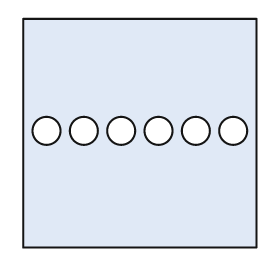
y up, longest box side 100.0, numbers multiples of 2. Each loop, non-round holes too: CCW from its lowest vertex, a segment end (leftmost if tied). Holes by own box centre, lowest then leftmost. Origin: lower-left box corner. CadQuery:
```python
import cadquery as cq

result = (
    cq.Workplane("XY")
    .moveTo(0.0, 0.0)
    .lineTo(100.0, 0.0)
    .lineTo(100.0, 98.0)
    .lineTo(0.0, 98.0)
    .close()
    .moveTo(10.0, 50.0)
    .circle(6.0)
    .moveTo(26.0, 50.0)
    .circle(6.0)
    .moveTo(42.0, 50.0)
    .circle(6.0)
    .moveTo(58.0, 50.0)
    .circle(6.0)
    .moveTo(74.0, 50.0)
    .circle(6.0)
    .moveTo(90.0, 50.0)
    .circle(6.0)
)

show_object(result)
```